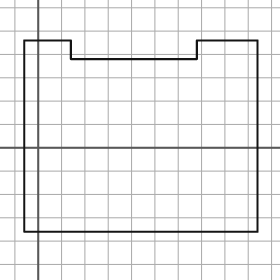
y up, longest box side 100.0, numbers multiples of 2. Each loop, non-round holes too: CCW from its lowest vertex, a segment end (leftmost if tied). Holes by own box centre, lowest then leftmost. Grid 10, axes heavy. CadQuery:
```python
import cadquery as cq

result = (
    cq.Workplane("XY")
    .moveTo(-6.0, -36.0)
    .lineTo(94.0, -36.0)
    .lineTo(94.0, 46.0)
    .lineTo(68.0, 46.0)
    .lineTo(68.0, 38.0)
    .lineTo(14.0, 38.0)
    .lineTo(14.0, 46.0)
    .lineTo(-6.0, 46.0)
    .close()
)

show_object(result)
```